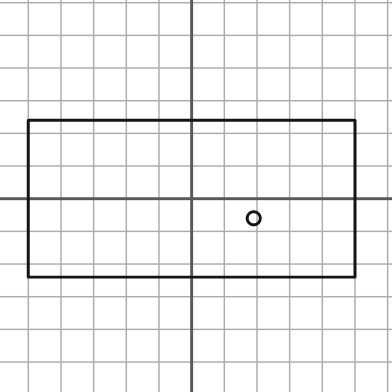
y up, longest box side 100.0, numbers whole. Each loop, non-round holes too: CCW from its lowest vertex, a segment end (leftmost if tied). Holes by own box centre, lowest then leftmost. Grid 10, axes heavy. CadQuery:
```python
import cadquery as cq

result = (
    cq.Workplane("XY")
    .moveTo(-50.0, -24.0)
    .lineTo(50.0, -24.0)
    .lineTo(50.0, 24.0)
    .lineTo(-50.0, 24.0)
    .close()
    .moveTo(19.0, -6.0)
    .circle(2.0)
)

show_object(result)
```